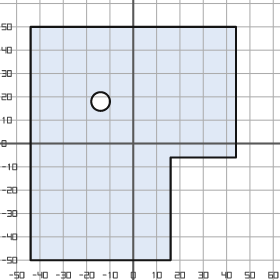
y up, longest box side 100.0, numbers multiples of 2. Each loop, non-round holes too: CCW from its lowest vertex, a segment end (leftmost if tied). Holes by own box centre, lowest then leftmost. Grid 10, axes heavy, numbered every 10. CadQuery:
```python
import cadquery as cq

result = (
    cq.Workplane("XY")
    .moveTo(-44.0, -50.0)
    .lineTo(16.0, -50.0)
    .lineTo(16.0, -6.0)
    .lineTo(44.0, -6.0)
    .lineTo(44.0, 50.0)
    .lineTo(-44.0, 50.0)
    .close()
    .moveTo(-14.0, 18.0)
    .circle(4.0)
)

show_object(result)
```